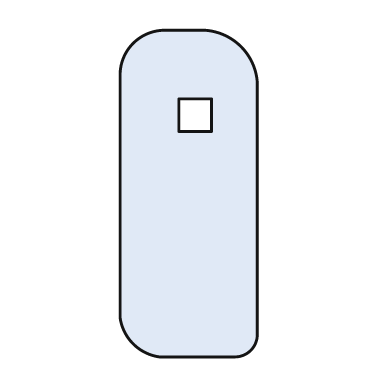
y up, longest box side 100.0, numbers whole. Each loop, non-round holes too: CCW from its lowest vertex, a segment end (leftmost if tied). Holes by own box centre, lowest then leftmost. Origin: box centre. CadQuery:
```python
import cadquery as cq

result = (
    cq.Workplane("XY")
    .moveTo(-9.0, -50.0)
    .lineTo(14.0, -50.0)
    .threePointArc((19.0, -48.0), (21.0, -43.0))
    .lineTo(21.0, 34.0)
    .threePointArc((16.0, 45.0), (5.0, 50.0))
    .lineTo(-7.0, 50.0)
    .threePointArc((-17.0, 46.0), (-21.0, 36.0))
    .lineTo(-21.0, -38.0)
    .threePointArc((-17.0, -46.0), (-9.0, -50.0))
    .close()
    .moveTo(-3.0, 19.0)
    .lineTo(7.0, 19.0)
    .lineTo(7.0, 29.0)
    .lineTo(-3.0, 29.0)
    .close()
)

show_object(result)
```